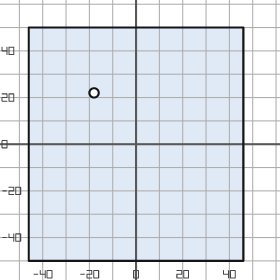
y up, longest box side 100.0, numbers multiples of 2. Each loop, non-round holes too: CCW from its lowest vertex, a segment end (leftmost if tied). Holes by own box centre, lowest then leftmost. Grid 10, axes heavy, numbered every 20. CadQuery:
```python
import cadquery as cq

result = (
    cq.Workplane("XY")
    .moveTo(-46.0, -50.0)
    .lineTo(46.0, -50.0)
    .lineTo(46.0, 50.0)
    .lineTo(-46.0, 50.0)
    .close()
    .moveTo(-18.0, 22.0)
    .circle(2.0)
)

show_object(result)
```